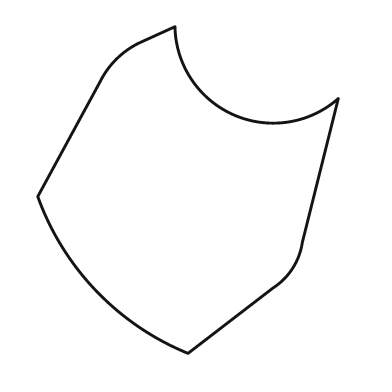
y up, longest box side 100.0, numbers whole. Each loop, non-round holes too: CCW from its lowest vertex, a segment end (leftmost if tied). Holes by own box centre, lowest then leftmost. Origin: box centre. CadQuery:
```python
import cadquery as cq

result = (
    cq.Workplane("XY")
    .moveTo(0.0, -50.0)
    .lineTo(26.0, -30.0)
    .threePointArc((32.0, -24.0), (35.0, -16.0))
    .lineTo(46.0, 28.0)
    .threePointArc((14.0, 23.0), (-4.0, 50.0))
    .lineTo(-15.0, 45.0)
    .threePointArc((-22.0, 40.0), (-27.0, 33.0))
    .lineTo(-46.0, -2.0)
    .threePointArc((-28.0, -31.0), (0.0, -50.0))
    .close()
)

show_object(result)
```